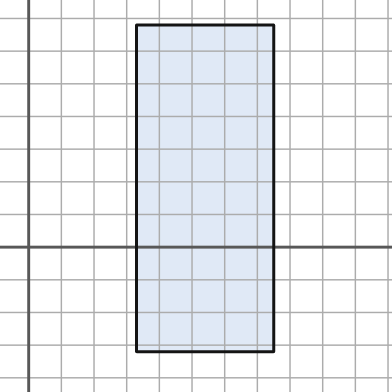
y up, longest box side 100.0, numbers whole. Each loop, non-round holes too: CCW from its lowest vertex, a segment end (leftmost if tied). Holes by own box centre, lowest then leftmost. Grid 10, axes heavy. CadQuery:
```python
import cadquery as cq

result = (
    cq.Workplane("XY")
    .moveTo(33.0, -32.0)
    .lineTo(75.0, -32.0)
    .lineTo(75.0, 68.0)
    .lineTo(33.0, 68.0)
    .close()
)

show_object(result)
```